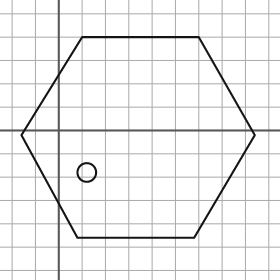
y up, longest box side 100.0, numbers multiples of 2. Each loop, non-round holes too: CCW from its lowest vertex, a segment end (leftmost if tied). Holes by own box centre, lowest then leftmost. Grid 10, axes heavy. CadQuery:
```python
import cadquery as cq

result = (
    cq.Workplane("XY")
    .moveTo(8.0, -46.0)
    .lineTo(58.0, -46.0)
    .lineTo(84.0, -2.0)
    .lineTo(60.0, 40.0)
    .lineTo(10.0, 40.0)
    .lineTo(-16.0, -2.0)
    .close()
    .moveTo(12.0, -18.0)
    .circle(4.0)
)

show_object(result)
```